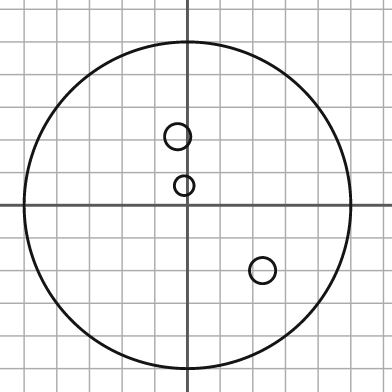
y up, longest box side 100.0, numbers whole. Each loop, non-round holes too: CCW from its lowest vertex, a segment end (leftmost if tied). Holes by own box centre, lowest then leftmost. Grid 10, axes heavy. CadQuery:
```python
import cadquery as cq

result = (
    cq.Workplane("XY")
    .moveTo(0.0, 0.0)
    .circle(50.0)
    .moveTo(23.0, -20.0)
    .circle(4.0)
    .moveTo(-1.0, 6.0)
    .circle(3.0)
    .moveTo(-3.0, 21.0)
    .circle(4.0)
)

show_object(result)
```